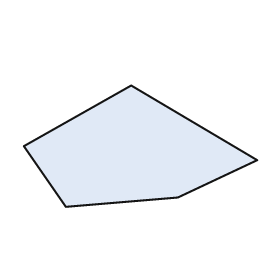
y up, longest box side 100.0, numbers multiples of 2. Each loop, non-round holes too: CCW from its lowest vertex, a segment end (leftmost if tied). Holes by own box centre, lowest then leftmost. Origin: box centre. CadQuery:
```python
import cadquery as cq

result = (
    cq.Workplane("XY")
    .moveTo(-32.0, -26.0)
    .lineTo(16.0, -22.0)
    .lineTo(50.0, -6.0)
    .lineTo(-4.0, 26.0)
    .lineTo(-50.0, 0.0)
    .close()
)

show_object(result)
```